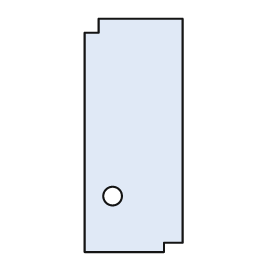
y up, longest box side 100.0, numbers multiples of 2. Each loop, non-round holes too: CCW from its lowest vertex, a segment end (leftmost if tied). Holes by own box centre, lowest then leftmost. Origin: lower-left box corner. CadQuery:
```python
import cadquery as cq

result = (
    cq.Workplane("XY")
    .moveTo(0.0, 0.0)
    .lineTo(34.0, 0.0)
    .lineTo(34.0, 4.0)
    .lineTo(42.0, 4.0)
    .lineTo(42.0, 100.0)
    .lineTo(6.0, 100.0)
    .lineTo(6.0, 94.0)
    .lineTo(0.0, 94.0)
    .close()
    .moveTo(12.0, 24.0)
    .circle(4.0)
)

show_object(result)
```